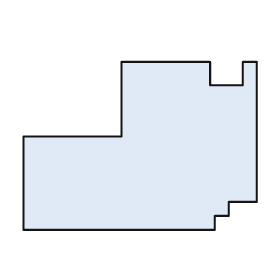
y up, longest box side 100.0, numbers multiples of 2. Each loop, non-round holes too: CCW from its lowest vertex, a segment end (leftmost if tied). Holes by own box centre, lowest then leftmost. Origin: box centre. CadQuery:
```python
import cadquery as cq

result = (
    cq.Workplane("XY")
    .moveTo(-50.0, -36.0)
    .lineTo(32.0, -36.0)
    .lineTo(32.0, -30.0)
    .lineTo(38.0, -30.0)
    .lineTo(38.0, -24.0)
    .lineTo(50.0, -24.0)
    .lineTo(50.0, 36.0)
    .lineTo(44.0, 36.0)
    .lineTo(44.0, 26.0)
    .lineTo(30.0, 26.0)
    .lineTo(30.0, 36.0)
    .lineTo(-8.0, 36.0)
    .lineTo(-8.0, 4.0)
    .lineTo(-50.0, 4.0)
    .close()
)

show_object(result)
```